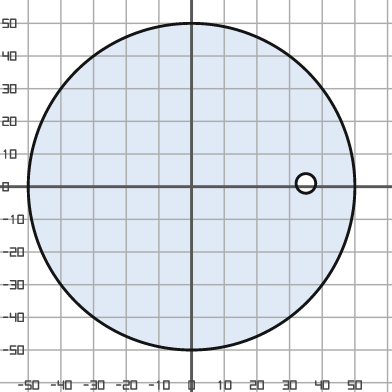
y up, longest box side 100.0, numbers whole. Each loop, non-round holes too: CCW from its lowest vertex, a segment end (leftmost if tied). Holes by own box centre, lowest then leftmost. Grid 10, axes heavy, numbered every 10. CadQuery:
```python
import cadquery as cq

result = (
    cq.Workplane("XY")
    .moveTo(0.0, 0.0)
    .circle(50.0)
    .moveTo(35.0, 1.0)
    .circle(3.0)
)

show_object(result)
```